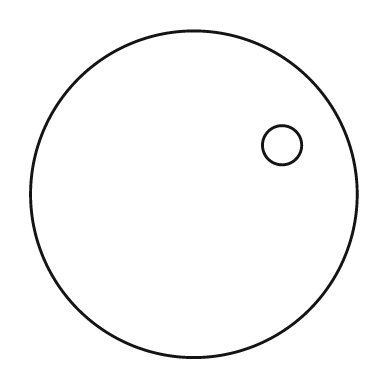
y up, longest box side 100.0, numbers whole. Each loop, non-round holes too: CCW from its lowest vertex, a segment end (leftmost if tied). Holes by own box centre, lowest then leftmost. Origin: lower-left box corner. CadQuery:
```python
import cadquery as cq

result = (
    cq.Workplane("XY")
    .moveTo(50.0, 50.0)
    .circle(50.0)
    .moveTo(77.0, 65.0)
    .circle(6.0)
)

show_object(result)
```